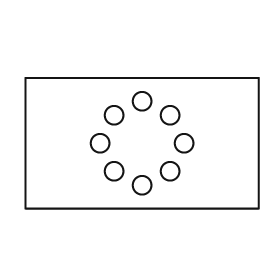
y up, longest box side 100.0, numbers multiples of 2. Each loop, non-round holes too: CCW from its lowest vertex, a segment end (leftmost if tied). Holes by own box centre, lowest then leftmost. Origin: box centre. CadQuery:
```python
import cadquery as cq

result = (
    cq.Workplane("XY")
    .moveTo(-50.0, -28.0)
    .lineTo(50.0, -28.0)
    .lineTo(50.0, 28.0)
    .lineTo(-50.0, 28.0)
    .close()
    .moveTo(0.0, -18.0)
    .circle(4.0)
    .moveTo(-12.0, -12.0)
    .circle(4.0)
    .moveTo(12.0, -12.0)
    .circle(4.0)
    .moveTo(-18.0, 0.0)
    .circle(4.0)
    .moveTo(18.0, 0.0)
    .circle(4.0)
    .moveTo(-12.0, 12.0)
    .circle(4.0)
    .moveTo(12.0, 12.0)
    .circle(4.0)
    .moveTo(0.0, 18.0)
    .circle(4.0)
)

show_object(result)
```